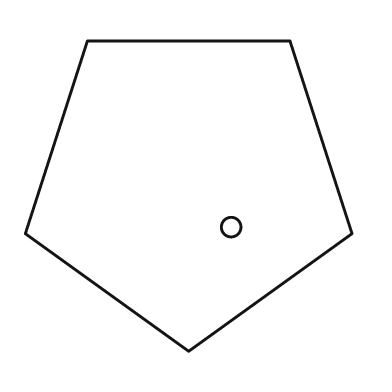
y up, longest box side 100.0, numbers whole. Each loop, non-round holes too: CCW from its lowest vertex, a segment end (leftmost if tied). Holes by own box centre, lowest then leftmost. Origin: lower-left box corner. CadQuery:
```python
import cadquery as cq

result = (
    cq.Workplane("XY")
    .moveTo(50.0, 0.0)
    .lineTo(100.0, 36.0)
    .lineTo(81.0, 95.0)
    .lineTo(19.0, 95.0)
    .lineTo(0.0, 36.0)
    .close()
    .moveTo(63.0, 38.0)
    .circle(3.0)
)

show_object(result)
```